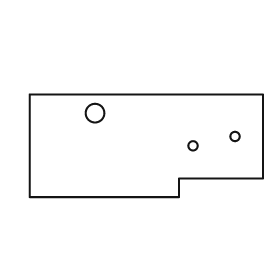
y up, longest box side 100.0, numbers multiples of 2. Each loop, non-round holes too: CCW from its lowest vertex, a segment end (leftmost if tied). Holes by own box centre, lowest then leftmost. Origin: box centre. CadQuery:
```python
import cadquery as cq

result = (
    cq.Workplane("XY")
    .moveTo(-50.0, -22.0)
    .lineTo(14.0, -22.0)
    .lineTo(14.0, -14.0)
    .lineTo(50.0, -14.0)
    .lineTo(50.0, 22.0)
    .lineTo(-50.0, 22.0)
    .close()
    .moveTo(20.0, 0.0)
    .circle(2.0)
    .moveTo(38.0, 4.0)
    .circle(2.0)
    .moveTo(-22.0, 14.0)
    .circle(4.0)
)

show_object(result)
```